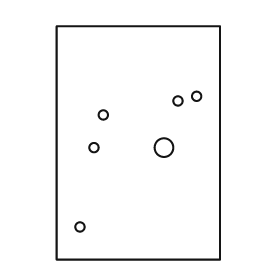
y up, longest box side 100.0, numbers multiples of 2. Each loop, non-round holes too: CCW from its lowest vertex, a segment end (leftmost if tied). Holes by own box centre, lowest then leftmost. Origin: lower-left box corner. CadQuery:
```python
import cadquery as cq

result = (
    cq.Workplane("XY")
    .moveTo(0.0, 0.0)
    .lineTo(70.0, 0.0)
    .lineTo(70.0, 100.0)
    .lineTo(0.0, 100.0)
    .close()
    .moveTo(10.0, 14.0)
    .circle(2.0)
    .moveTo(16.0, 48.0)
    .circle(2.0)
    .moveTo(46.0, 48.0)
    .circle(4.0)
    .moveTo(20.0, 62.0)
    .circle(2.0)
    .moveTo(52.0, 68.0)
    .circle(2.0)
    .moveTo(60.0, 70.0)
    .circle(2.0)
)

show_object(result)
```